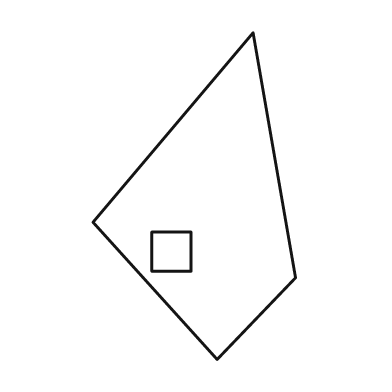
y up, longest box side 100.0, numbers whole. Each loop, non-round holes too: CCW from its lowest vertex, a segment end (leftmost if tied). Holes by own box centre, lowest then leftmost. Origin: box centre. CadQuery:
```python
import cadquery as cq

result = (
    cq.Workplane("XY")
    .moveTo(7.0, -50.0)
    .lineTo(31.0, -25.0)
    .lineTo(18.0, 50.0)
    .lineTo(-31.0, -8.0)
    .close()
    .moveTo(-13.0, -23.0)
    .lineTo(-1.0, -23.0)
    .lineTo(-1.0, -11.0)
    .lineTo(-13.0, -11.0)
    .close()
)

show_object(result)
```